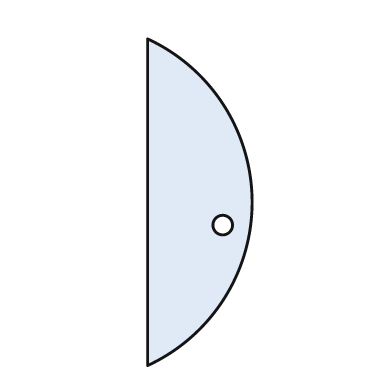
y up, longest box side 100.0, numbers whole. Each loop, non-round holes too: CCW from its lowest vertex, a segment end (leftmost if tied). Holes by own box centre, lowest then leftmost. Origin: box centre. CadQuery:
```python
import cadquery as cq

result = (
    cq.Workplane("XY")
    .moveTo(-16.0, -50.0)
    .threePointArc((16.0, 0.0), (-16.0, 50.0))
    .close()
    .moveTo(7.0, -7.0)
    .circle(3.0)
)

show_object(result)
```